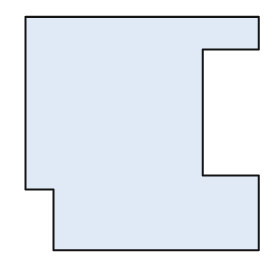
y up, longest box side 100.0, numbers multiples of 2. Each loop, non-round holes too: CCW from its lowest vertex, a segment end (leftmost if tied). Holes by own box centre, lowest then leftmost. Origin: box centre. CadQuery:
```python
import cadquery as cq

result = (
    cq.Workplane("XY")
    .moveTo(-38.0, -50.0)
    .lineTo(50.0, -50.0)
    .lineTo(50.0, -18.0)
    .lineTo(26.0, -18.0)
    .lineTo(26.0, 36.0)
    .lineTo(50.0, 36.0)
    .lineTo(50.0, 50.0)
    .lineTo(-50.0, 50.0)
    .lineTo(-50.0, -24.0)
    .lineTo(-38.0, -24.0)
    .close()
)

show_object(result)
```